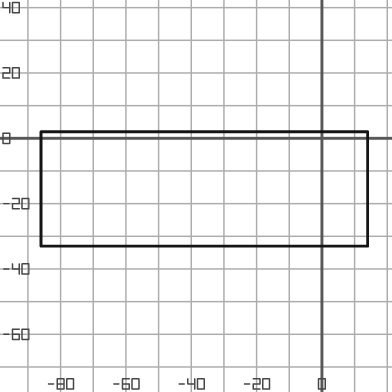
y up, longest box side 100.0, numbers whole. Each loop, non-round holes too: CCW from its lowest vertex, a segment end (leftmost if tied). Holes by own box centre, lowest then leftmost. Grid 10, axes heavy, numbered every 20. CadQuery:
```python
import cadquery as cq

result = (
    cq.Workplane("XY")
    .moveTo(-86.0, -33.0)
    .lineTo(14.0, -33.0)
    .lineTo(14.0, 2.0)
    .lineTo(-86.0, 2.0)
    .close()
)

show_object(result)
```